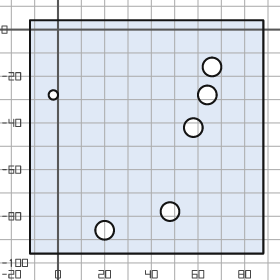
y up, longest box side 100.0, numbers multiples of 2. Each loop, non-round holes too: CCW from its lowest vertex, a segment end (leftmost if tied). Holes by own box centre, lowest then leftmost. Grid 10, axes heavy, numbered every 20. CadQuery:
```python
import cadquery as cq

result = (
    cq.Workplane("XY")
    .moveTo(-12.0, -96.0)
    .lineTo(88.0, -96.0)
    .lineTo(88.0, 4.0)
    .lineTo(-12.0, 4.0)
    .close()
    .moveTo(20.0, -86.0)
    .circle(4.0)
    .moveTo(48.0, -78.0)
    .circle(4.0)
    .moveTo(58.0, -42.0)
    .circle(4.0)
    .moveTo(-2.0, -28.0)
    .circle(2.0)
    .moveTo(64.0, -28.0)
    .circle(4.0)
    .moveTo(66.0, -16.0)
    .circle(4.0)
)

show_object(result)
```